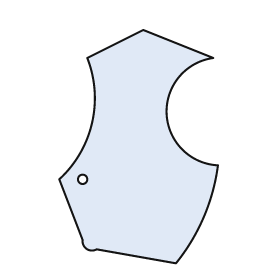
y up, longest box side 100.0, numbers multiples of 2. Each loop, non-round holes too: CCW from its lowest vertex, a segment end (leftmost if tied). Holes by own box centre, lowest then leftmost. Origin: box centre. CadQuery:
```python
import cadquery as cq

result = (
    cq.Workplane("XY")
    .moveTo(16.0, -50.0)
    .threePointArc((28.0, -30.0), (34.0, -8.0))
    .threePointArc((12.0, 14.0), (32.0, 38.0))
    .lineTo(2.0, 50.0)
    .lineTo(-22.0, 38.0)
    .threePointArc((-20.0, 10.0), (-34.0, -14.0))
    .lineTo(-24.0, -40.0)
    .threePointArc((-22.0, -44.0), (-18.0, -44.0))
    .close()
    .moveTo(-24.0, -14.0)
    .circle(2.0)
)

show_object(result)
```